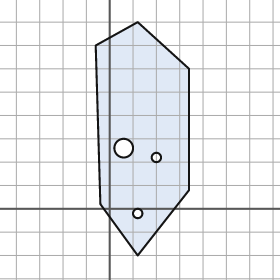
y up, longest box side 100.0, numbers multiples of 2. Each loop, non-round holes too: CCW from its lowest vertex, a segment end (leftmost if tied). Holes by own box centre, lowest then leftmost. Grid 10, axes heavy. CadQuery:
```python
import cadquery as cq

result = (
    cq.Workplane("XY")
    .moveTo(12.0, -20.0)
    .lineTo(34.0, 8.0)
    .lineTo(34.0, 60.0)
    .lineTo(12.0, 80.0)
    .lineTo(-6.0, 70.0)
    .lineTo(-4.0, 2.0)
    .close()
    .moveTo(12.0, -2.0)
    .circle(2.0)
    .moveTo(20.0, 22.0)
    .circle(2.0)
    .moveTo(6.0, 26.0)
    .circle(4.0)
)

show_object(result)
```